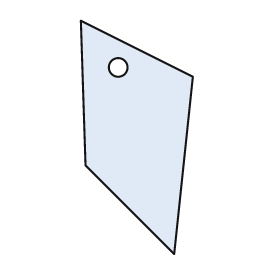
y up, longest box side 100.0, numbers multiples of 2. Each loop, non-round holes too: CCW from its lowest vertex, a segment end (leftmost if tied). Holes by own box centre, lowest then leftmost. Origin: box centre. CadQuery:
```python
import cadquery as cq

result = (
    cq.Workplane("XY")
    .moveTo(16.0, -50.0)
    .lineTo(24.0, 26.0)
    .lineTo(-24.0, 50.0)
    .lineTo(-22.0, -12.0)
    .close()
    .moveTo(-8.0, 30.0)
    .circle(4.0)
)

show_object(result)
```